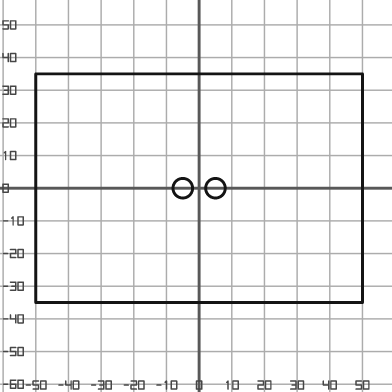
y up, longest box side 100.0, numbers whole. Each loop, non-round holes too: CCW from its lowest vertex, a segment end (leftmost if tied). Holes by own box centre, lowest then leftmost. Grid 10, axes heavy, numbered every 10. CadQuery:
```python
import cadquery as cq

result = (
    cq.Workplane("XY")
    .moveTo(-50.0, -35.0)
    .lineTo(50.0, -35.0)
    .lineTo(50.0, 35.0)
    .lineTo(-50.0, 35.0)
    .close()
    .moveTo(-5.0, 0.0)
    .circle(3.0)
    .moveTo(5.0, 0.0)
    .circle(3.0)
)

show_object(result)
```